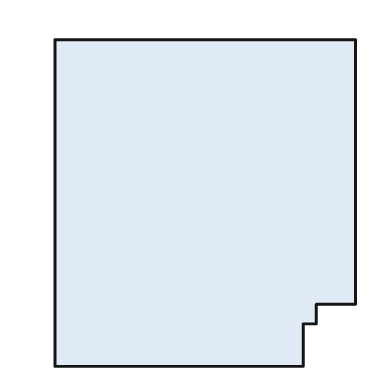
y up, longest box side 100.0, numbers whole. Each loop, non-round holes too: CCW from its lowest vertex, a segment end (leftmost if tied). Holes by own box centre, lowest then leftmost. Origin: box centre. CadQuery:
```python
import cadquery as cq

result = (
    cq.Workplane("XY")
    .moveTo(-46.0, -50.0)
    .lineTo(30.0, -50.0)
    .lineTo(30.0, -37.0)
    .lineTo(34.0, -37.0)
    .lineTo(34.0, -31.0)
    .lineTo(46.0, -31.0)
    .lineTo(46.0, 50.0)
    .lineTo(-46.0, 50.0)
    .close()
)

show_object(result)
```